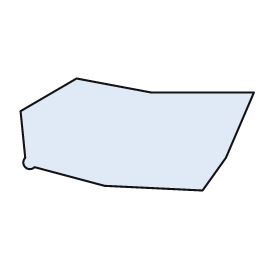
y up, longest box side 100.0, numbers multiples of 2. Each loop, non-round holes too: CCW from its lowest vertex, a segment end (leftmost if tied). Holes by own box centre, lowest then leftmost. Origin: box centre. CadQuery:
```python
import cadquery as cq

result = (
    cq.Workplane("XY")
    .moveTo(28.0, -24.0)
    .lineTo(38.0, -10.0)
    .lineTo(50.0, 18.0)
    .lineTo(6.0, 18.0)
    .lineTo(-26.0, 24.0)
    .lineTo(-50.0, 10.0)
    .lineTo(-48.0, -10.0)
    .threePointArc((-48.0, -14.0), (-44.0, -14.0))
    .lineTo(-14.0, -22.0)
    .close()
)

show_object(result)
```